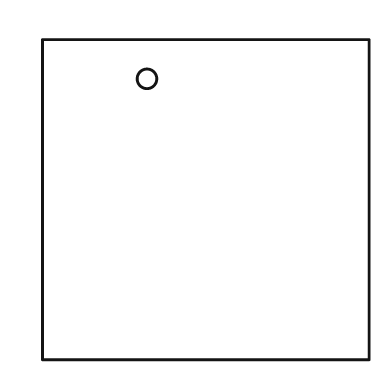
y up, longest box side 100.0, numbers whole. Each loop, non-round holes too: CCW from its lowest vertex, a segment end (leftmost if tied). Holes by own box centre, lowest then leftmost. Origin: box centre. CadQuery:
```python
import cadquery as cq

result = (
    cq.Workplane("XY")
    .moveTo(-50.0, -49.0)
    .lineTo(50.0, -49.0)
    .lineTo(50.0, 49.0)
    .lineTo(-50.0, 49.0)
    .close()
    .moveTo(-18.0, 37.0)
    .circle(3.0)
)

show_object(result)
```